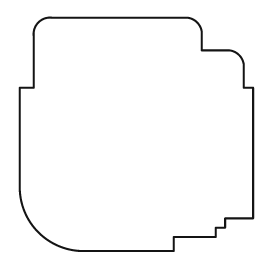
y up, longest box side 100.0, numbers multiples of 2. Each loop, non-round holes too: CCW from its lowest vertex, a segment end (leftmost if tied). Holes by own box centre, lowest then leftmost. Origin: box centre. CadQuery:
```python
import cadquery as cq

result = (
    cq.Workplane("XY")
    .moveTo(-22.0, -50.0)
    .lineTo(16.0, -50.0)
    .lineTo(16.0, -44.0)
    .lineTo(34.0, -44.0)
    .lineTo(34.0, -40.0)
    .lineTo(38.0, -40.0)
    .lineTo(38.0, -36.0)
    .lineTo(50.0, -36.0)
    .lineTo(50.0, 20.0)
    .lineTo(46.0, 20.0)
    .lineTo(46.0, 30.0)
    .threePointArc((44.0, 34.0), (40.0, 36.0))
    .lineTo(28.0, 36.0)
    .lineTo(28.0, 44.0)
    .threePointArc((26.0, 48.0), (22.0, 50.0))
    .lineTo(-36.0, 50.0)
    .threePointArc((-42.0, 48.0), (-44.0, 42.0))
    .lineTo(-44.0, 20.0)
    .lineTo(-50.0, 20.0)
    .lineTo(-50.0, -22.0)
    .threePointArc((-42.0, -42.0), (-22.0, -50.0))
    .close()
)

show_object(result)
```